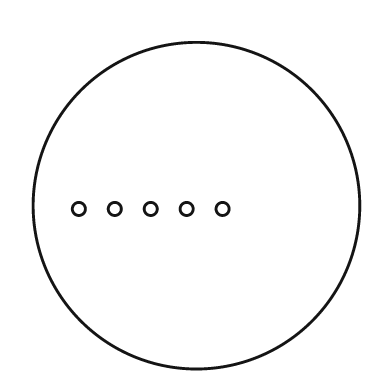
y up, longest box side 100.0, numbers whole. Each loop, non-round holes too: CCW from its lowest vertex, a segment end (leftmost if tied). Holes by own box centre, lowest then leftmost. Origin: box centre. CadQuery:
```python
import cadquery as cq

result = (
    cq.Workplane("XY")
    .moveTo(0.0, 0.0)
    .circle(50.0)
    .moveTo(-36.0, -1.0)
    .circle(2.0)
    .moveTo(-25.0, -1.0)
    .circle(2.0)
    .moveTo(-14.0, -1.0)
    .circle(2.0)
    .moveTo(-3.0, -1.0)
    .circle(2.0)
    .moveTo(8.0, -1.0)
    .circle(2.0)
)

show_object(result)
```